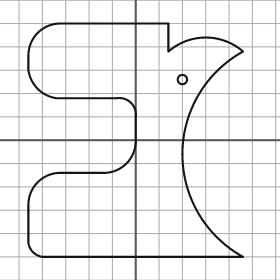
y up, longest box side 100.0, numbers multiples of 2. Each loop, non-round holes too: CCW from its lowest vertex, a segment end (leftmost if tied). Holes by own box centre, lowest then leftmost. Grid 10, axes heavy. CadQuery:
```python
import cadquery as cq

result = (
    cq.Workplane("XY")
    .moveTo(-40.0, -50.0)
    .lineTo(46.0, -50.0)
    .threePointArc((20.0, -6.0), (46.0, 38.0))
    .threePointArc((30.0, 44.0), (14.0, 38.0))
    .lineTo(14.0, 50.0)
    .lineTo(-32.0, 50.0)
    .threePointArc((-42.0, 46.0), (-46.0, 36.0))
    .lineTo(-46.0, 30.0)
    .threePointArc((-42.0, 22.0), (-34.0, 18.0))
    .lineTo(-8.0, 18.0)
    .threePointArc((-2.0, 16.0), (0.0, 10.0))
    .lineTo(0.0, 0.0)
    .threePointArc((-4.0, -10.0), (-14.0, -14.0))
    .lineTo(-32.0, -14.0)
    .threePointArc((-42.0, -18.0), (-46.0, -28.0))
    .lineTo(-46.0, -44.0)
    .threePointArc((-44.0, -48.0), (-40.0, -50.0))
    .close()
    .moveTo(20.0, 26.0)
    .circle(2.0)
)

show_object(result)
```